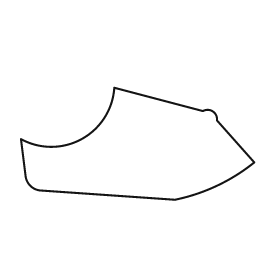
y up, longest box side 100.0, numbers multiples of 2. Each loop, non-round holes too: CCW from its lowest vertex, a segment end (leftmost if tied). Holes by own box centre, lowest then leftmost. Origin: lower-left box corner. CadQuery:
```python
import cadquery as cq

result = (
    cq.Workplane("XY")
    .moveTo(66.0, 0.0)
    .threePointArc((84.0, 6.0), (100.0, 16.0))
    .lineTo(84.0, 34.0)
    .threePointArc((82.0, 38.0), (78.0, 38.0))
    .lineTo(40.0, 48.0)
    .threePointArc((26.0, 26.0), (0.0, 26.0))
    .lineTo(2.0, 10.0)
    .threePointArc((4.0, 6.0), (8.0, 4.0))
    .close()
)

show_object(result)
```